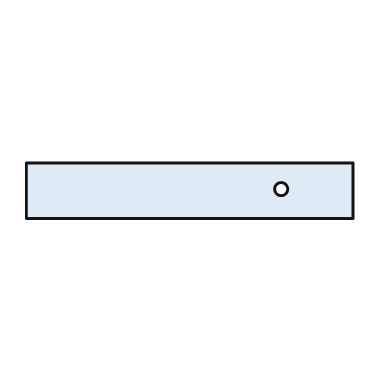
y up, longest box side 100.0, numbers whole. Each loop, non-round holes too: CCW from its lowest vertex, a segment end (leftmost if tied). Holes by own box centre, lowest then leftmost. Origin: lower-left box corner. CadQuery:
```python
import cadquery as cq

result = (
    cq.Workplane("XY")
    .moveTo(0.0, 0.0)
    .lineTo(100.0, 0.0)
    .lineTo(100.0, 17.0)
    .lineTo(0.0, 17.0)
    .close()
    .moveTo(78.0, 9.0)
    .circle(2.0)
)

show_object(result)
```